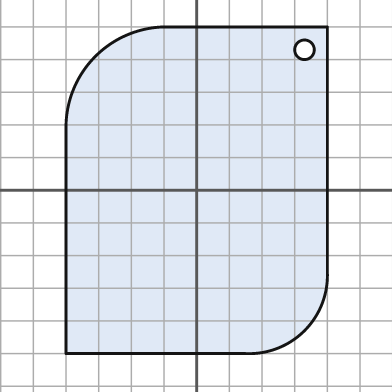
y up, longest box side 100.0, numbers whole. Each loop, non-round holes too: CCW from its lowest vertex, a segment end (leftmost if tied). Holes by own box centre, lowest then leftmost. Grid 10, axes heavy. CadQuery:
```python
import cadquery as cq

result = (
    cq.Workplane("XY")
    .moveTo(-40.0, -50.0)
    .lineTo(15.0, -50.0)
    .threePointArc((33.0, -43.0), (40.0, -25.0))
    .lineTo(40.0, 50.0)
    .lineTo(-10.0, 50.0)
    .threePointArc((-31.0, 41.0), (-40.0, 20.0))
    .close()
    .moveTo(33.0, 43.0)
    .circle(3.0)
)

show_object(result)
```